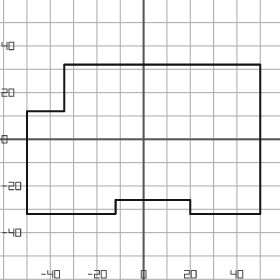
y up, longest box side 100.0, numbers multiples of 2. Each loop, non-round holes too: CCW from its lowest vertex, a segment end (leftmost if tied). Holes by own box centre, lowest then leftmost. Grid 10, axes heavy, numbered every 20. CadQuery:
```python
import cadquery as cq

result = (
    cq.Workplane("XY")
    .moveTo(-50.0, -32.0)
    .lineTo(-12.0, -32.0)
    .lineTo(-12.0, -26.0)
    .lineTo(20.0, -26.0)
    .lineTo(20.0, -32.0)
    .lineTo(50.0, -32.0)
    .lineTo(50.0, 32.0)
    .lineTo(-34.0, 32.0)
    .lineTo(-34.0, 12.0)
    .lineTo(-50.0, 12.0)
    .close()
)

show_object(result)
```